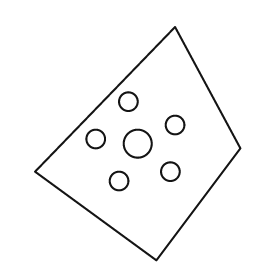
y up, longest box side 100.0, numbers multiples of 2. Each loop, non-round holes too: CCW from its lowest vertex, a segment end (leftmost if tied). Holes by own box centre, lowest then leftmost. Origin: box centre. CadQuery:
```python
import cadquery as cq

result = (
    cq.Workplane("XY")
    .moveTo(8.0, -50.0)
    .lineTo(44.0, -2.0)
    .lineTo(16.0, 50.0)
    .lineTo(-44.0, -12.0)
    .close()
    .moveTo(-8.0, -16.0)
    .circle(4.0)
    .moveTo(14.0, -12.0)
    .circle(4.0)
    .moveTo(0.0, 0.0)
    .circle(6.0)
    .moveTo(-18.0, 2.0)
    .circle(4.0)
    .moveTo(16.0, 8.0)
    .circle(4.0)
    .moveTo(-4.0, 18.0)
    .circle(4.0)
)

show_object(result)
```